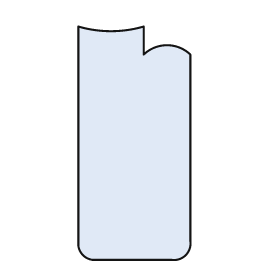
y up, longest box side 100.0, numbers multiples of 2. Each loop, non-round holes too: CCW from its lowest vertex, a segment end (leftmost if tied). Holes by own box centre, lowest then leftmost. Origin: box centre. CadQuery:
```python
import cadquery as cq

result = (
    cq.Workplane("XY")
    .moveTo(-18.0, -50.0)
    .lineTo(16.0, -50.0)
    .threePointArc((22.0, -48.0), (24.0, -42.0))
    .lineTo(24.0, 38.0)
    .threePointArc((14.0, 42.0), (4.0, 38.0))
    .lineTo(4.0, 50.0)
    .threePointArc((-10.0, 48.0), (-24.0, 50.0))
    .lineTo(-24.0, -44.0)
    .threePointArc((-22.0, -48.0), (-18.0, -50.0))
    .close()
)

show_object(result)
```